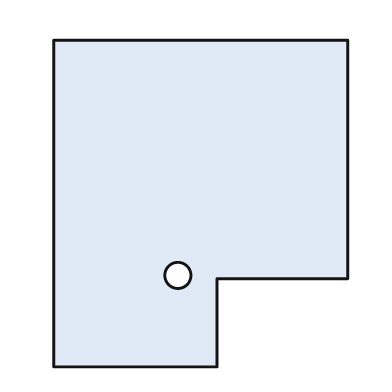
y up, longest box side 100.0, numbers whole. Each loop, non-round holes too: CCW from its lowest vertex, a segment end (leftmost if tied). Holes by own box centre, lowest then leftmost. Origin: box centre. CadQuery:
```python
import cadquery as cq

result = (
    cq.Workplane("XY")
    .moveTo(-45.0, -50.0)
    .lineTo(5.0, -50.0)
    .lineTo(5.0, -23.0)
    .lineTo(45.0, -23.0)
    .lineTo(45.0, 50.0)
    .lineTo(-45.0, 50.0)
    .close()
    .moveTo(-7.0, -22.0)
    .circle(4.0)
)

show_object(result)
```